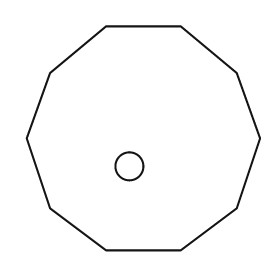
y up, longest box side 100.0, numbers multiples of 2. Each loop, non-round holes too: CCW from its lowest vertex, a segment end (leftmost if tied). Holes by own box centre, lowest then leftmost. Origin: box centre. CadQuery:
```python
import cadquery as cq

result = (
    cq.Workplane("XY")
    .moveTo(-16.0, -48.0)
    .lineTo(16.0, -48.0)
    .lineTo(40.0, -30.0)
    .lineTo(50.0, 0.0)
    .lineTo(40.0, 28.0)
    .lineTo(16.0, 48.0)
    .lineTo(-16.0, 48.0)
    .lineTo(-40.0, 28.0)
    .lineTo(-50.0, 0.0)
    .lineTo(-40.0, -30.0)
    .close()
    .moveTo(-6.0, -12.0)
    .circle(6.0)
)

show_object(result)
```